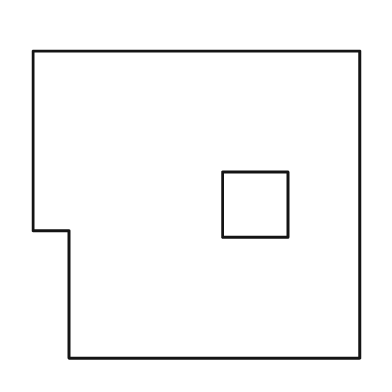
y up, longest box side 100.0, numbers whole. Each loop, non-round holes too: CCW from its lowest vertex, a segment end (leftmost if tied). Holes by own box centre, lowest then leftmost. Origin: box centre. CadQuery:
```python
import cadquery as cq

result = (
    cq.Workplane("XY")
    .moveTo(-39.0, -47.0)
    .lineTo(50.0, -47.0)
    .lineTo(50.0, 47.0)
    .lineTo(-50.0, 47.0)
    .lineTo(-50.0, -8.0)
    .lineTo(-39.0, -8.0)
    .close()
    .moveTo(8.0, -10.0)
    .lineTo(28.0, -10.0)
    .lineTo(28.0, 10.0)
    .lineTo(8.0, 10.0)
    .close()
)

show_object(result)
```